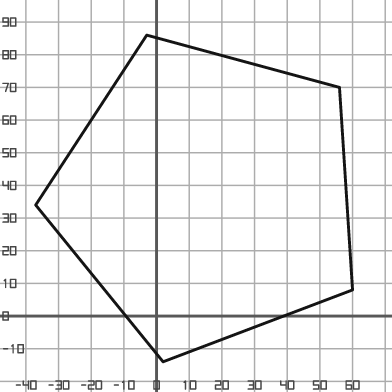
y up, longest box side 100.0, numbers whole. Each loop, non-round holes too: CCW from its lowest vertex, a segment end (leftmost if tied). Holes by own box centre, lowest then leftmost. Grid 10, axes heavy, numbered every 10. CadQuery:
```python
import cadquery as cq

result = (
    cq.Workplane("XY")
    .moveTo(2.0, -14.0)
    .lineTo(60.0, 8.0)
    .lineTo(56.0, 70.0)
    .lineTo(-3.0, 86.0)
    .lineTo(-37.0, 34.0)
    .close()
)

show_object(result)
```